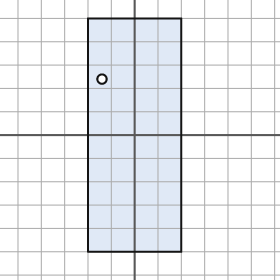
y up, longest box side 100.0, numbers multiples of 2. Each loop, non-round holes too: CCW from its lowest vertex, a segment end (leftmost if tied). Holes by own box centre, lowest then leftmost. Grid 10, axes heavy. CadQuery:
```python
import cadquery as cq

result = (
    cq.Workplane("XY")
    .moveTo(-20.0, -50.0)
    .lineTo(20.0, -50.0)
    .lineTo(20.0, 50.0)
    .lineTo(-20.0, 50.0)
    .close()
    .moveTo(-14.0, 24.0)
    .circle(2.0)
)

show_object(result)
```